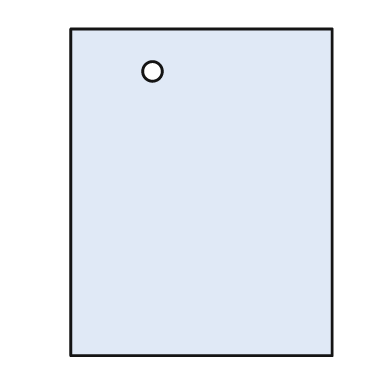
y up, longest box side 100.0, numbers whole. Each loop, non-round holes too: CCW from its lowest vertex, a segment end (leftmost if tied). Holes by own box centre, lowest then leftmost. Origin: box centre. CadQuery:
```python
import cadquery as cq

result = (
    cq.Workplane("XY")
    .moveTo(-40.0, -50.0)
    .lineTo(40.0, -50.0)
    .lineTo(40.0, 50.0)
    .lineTo(-40.0, 50.0)
    .close()
    .moveTo(-15.0, 37.0)
    .circle(3.0)
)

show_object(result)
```